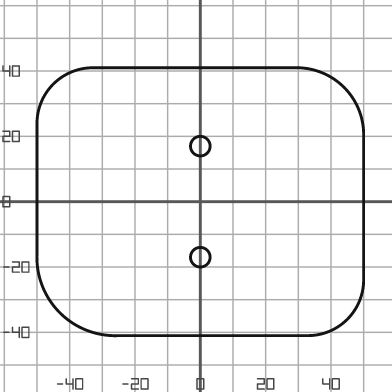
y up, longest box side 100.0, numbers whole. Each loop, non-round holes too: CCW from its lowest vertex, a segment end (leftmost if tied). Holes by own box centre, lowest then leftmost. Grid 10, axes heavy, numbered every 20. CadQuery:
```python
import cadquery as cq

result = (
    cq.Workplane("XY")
    .moveTo(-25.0, -41.0)
    .lineTo(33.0, -41.0)
    .threePointArc((45.0, -36.0), (50.0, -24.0))
    .lineTo(50.0, 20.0)
    .threePointArc((44.0, 35.0), (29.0, 41.0))
    .lineTo(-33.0, 41.0)
    .threePointArc((-45.0, 36.0), (-50.0, 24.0))
    .lineTo(-50.0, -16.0)
    .threePointArc((-43.0, -34.0), (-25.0, -41.0))
    .close()
    .moveTo(0.0, -17.0)
    .circle(3.0)
    .moveTo(0.0, 17.0)
    .circle(3.0)
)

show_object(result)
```